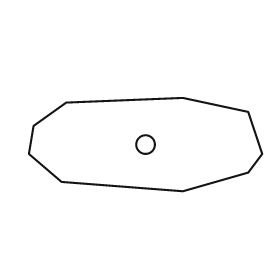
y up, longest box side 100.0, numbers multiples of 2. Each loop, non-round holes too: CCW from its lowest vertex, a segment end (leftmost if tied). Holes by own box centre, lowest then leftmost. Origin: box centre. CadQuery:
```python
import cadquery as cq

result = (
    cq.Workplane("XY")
    .moveTo(16.0, -20.0)
    .lineTo(44.0, -12.0)
    .lineTo(50.0, -4.0)
    .lineTo(44.0, 14.0)
    .lineTo(16.0, 20.0)
    .lineTo(-34.0, 18.0)
    .lineTo(-48.0, 8.0)
    .lineTo(-50.0, -4.0)
    .lineTo(-36.0, -16.0)
    .close()
    .moveTo(0.0, 0.0)
    .circle(4.0)
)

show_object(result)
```